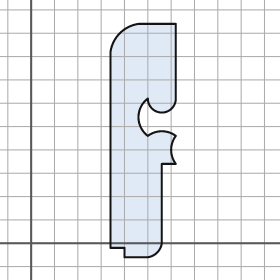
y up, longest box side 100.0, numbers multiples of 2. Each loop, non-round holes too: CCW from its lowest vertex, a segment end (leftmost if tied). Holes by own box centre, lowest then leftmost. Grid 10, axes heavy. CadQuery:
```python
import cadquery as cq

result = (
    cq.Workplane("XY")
    .moveTo(40.0, -6.0)
    .lineTo(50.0, -6.0)
    .threePointArc((54.0, -4.0), (56.0, 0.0))
    .lineTo(56.0, 34.0)
    .lineTo(62.0, 34.0)
    .threePointArc((60.0, 40.0), (62.0, 46.0))
    .threePointArc((56.0, 48.0), (50.0, 46.0))
    .threePointArc((46.0, 54.0), (50.0, 62.0))
    .threePointArc((56.0, 56.0), (62.0, 62.0))
    .lineTo(62.0, 94.0)
    .lineTo(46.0, 94.0)
    .threePointArc((38.0, 90.0), (34.0, 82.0))
    .lineTo(34.0, -2.0)
    .lineTo(40.0, -2.0)
    .close()
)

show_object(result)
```